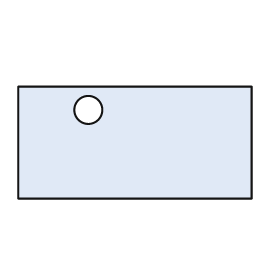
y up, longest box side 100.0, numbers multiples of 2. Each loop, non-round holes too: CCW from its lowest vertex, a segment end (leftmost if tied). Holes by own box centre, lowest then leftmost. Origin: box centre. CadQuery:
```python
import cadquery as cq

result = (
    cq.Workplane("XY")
    .moveTo(-50.0, -24.0)
    .lineTo(50.0, -24.0)
    .lineTo(50.0, 24.0)
    .lineTo(-50.0, 24.0)
    .close()
    .moveTo(-20.0, 14.0)
    .circle(6.0)
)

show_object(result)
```